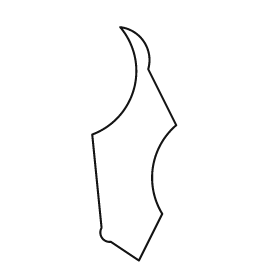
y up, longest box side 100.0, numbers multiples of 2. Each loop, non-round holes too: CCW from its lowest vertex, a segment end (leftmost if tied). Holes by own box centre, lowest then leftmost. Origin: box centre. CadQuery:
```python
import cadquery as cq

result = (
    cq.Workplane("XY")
    .moveTo(2.0, -50.0)
    .lineTo(12.0, -30.0)
    .threePointArc((8.0, -10.0), (18.0, 8.0))
    .lineTo(6.0, 32.0)
    .threePointArc((4.0, 44.0), (-6.0, 50.0))
    .threePointArc((0.0, 24.0), (-18.0, 4.0))
    .lineTo(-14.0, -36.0)
    .threePointArc((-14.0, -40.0), (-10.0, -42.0))
    .close()
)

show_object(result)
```